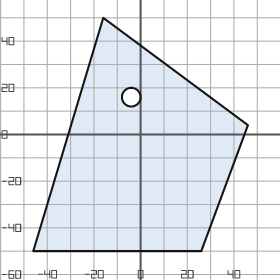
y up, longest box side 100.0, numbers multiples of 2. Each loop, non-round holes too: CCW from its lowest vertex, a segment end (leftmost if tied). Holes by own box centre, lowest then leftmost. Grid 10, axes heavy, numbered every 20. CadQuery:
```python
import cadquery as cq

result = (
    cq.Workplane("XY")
    .moveTo(-46.0, -50.0)
    .lineTo(26.0, -50.0)
    .lineTo(46.0, 4.0)
    .lineTo(-16.0, 50.0)
    .close()
    .moveTo(-4.0, 16.0)
    .circle(4.0)
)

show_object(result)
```